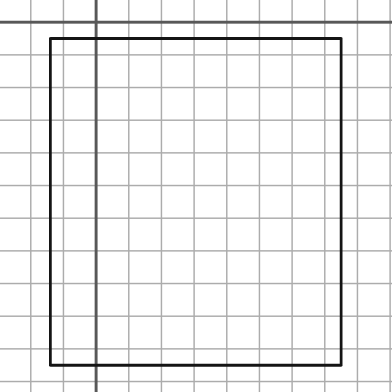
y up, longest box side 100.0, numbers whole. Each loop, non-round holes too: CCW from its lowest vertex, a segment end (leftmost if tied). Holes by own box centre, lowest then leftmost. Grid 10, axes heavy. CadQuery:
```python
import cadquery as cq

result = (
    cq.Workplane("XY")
    .moveTo(-14.0, -105.0)
    .lineTo(75.0, -105.0)
    .lineTo(75.0, -5.0)
    .lineTo(-14.0, -5.0)
    .close()
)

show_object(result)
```